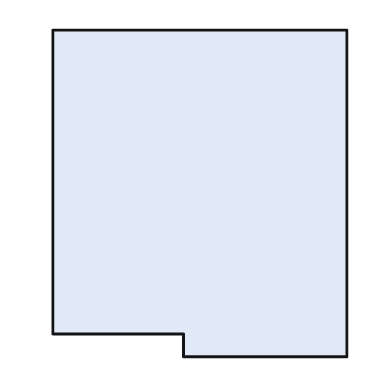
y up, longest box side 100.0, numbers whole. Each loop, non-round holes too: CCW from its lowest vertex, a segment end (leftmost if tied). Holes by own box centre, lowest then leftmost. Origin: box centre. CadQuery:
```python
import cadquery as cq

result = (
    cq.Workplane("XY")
    .moveTo(-5.0, -50.0)
    .lineTo(45.0, -50.0)
    .lineTo(45.0, 50.0)
    .lineTo(-45.0, 50.0)
    .lineTo(-45.0, -43.0)
    .lineTo(-5.0, -43.0)
    .close()
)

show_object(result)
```